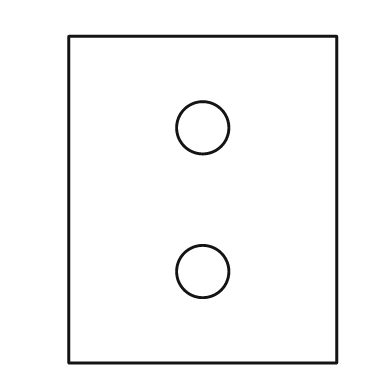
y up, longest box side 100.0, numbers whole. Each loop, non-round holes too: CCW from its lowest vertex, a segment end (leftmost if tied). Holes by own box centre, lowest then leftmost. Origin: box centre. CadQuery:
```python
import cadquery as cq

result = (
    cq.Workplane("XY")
    .moveTo(-41.0, -50.0)
    .lineTo(41.0, -50.0)
    .lineTo(41.0, 50.0)
    .lineTo(-41.0, 50.0)
    .close()
    .moveTo(0.0, -22.0)
    .circle(8.0)
    .moveTo(0.0, 22.0)
    .circle(8.0)
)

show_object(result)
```